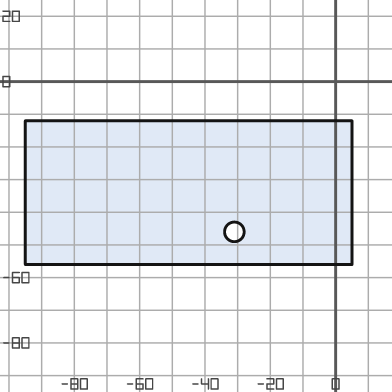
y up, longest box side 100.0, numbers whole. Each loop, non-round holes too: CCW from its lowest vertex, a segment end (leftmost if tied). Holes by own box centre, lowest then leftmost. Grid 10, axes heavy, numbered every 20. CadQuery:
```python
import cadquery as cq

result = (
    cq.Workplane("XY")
    .moveTo(-95.0, -56.0)
    .lineTo(5.0, -56.0)
    .lineTo(5.0, -12.0)
    .lineTo(-95.0, -12.0)
    .close()
    .moveTo(-31.0, -46.0)
    .circle(3.0)
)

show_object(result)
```